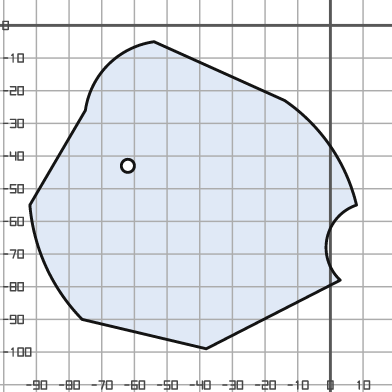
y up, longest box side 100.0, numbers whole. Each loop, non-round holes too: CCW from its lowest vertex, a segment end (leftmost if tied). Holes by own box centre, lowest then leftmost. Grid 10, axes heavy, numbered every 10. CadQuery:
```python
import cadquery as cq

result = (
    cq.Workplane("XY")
    .moveTo(-38.0, -99.0)
    .lineTo(3.0, -78.0)
    .threePointArc((-1.0, -65.0), (8.0, -55.0))
    .threePointArc((0.0, -37.0), (-14.0, -23.0))
    .lineTo(-54.0, -5.0)
    .threePointArc((-68.0, -12.0), (-75.0, -26.0))
    .lineTo(-92.0, -55.0)
    .threePointArc((-87.0, -74.0), (-76.0, -90.0))
    .close()
    .moveTo(-62.0, -43.0)
    .circle(2.0)
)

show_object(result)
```